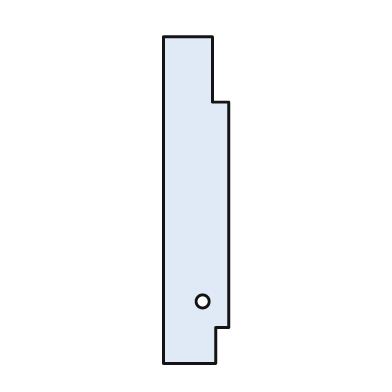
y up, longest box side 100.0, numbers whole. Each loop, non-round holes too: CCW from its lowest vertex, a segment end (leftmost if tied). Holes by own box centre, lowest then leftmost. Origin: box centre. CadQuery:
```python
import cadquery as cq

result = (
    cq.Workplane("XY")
    .moveTo(-10.0, -50.0)
    .lineTo(6.0, -50.0)
    .lineTo(6.0, -39.0)
    .lineTo(10.0, -39.0)
    .lineTo(10.0, 30.0)
    .lineTo(5.0, 30.0)
    .lineTo(5.0, 50.0)
    .lineTo(-10.0, 50.0)
    .close()
    .moveTo(2.0, -31.0)
    .circle(2.0)
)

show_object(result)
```